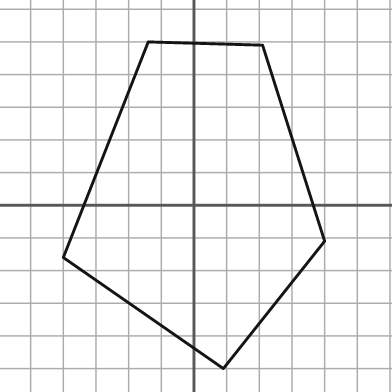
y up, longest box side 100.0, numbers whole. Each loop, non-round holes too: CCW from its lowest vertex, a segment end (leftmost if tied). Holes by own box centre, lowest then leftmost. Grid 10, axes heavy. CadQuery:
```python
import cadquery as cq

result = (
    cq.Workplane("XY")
    .moveTo(9.0, -50.0)
    .lineTo(40.0, -11.0)
    .lineTo(21.0, 49.0)
    .lineTo(-14.0, 50.0)
    .lineTo(-40.0, -16.0)
    .close()
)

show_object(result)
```